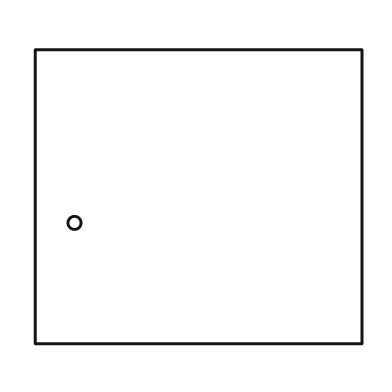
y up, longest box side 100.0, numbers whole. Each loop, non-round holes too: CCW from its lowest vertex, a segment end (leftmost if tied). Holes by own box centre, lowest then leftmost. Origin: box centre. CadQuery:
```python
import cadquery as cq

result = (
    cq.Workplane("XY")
    .moveTo(-50.0, -45.0)
    .lineTo(50.0, -45.0)
    .lineTo(50.0, 45.0)
    .lineTo(-50.0, 45.0)
    .close()
    .moveTo(-38.0, -8.0)
    .circle(2.0)
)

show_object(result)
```